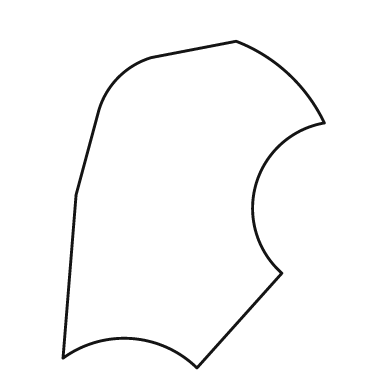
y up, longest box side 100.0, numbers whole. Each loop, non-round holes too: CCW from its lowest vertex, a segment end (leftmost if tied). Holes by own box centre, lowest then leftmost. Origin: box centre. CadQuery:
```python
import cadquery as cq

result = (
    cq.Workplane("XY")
    .moveTo(1.0, -50.0)
    .lineTo(27.0, -21.0)
    .threePointArc((19.0, 6.0), (40.0, 25.0))
    .threePointArc((29.0, 40.0), (13.0, 50.0))
    .lineTo(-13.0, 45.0)
    .threePointArc((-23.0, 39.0), (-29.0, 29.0))
    .lineTo(-36.0, 3.0)
    .lineTo(-40.0, -47.0)
    .threePointArc((-19.0, -41.0), (1.0, -50.0))
    .close()
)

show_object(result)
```